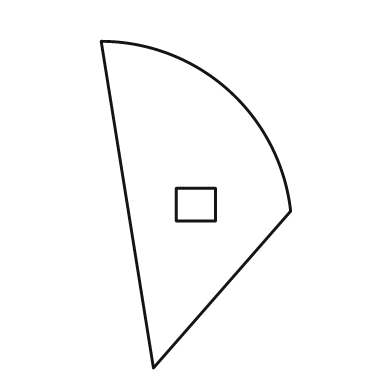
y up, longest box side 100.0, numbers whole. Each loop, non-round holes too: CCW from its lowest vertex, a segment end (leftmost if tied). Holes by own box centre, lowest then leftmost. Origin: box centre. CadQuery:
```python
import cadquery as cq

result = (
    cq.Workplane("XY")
    .moveTo(-13.0, -50.0)
    .lineTo(29.0, -2.0)
    .threePointArc((10.0, 35.0), (-29.0, 50.0))
    .close()
    .moveTo(-6.0, -5.0)
    .lineTo(6.0, -5.0)
    .lineTo(6.0, 5.0)
    .lineTo(-6.0, 5.0)
    .close()
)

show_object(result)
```